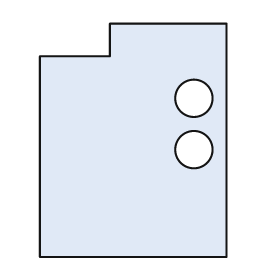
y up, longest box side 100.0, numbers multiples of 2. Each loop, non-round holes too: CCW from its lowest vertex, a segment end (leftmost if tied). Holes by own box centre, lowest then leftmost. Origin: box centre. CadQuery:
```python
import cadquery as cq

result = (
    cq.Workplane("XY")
    .moveTo(-40.0, -50.0)
    .lineTo(40.0, -50.0)
    .lineTo(40.0, 50.0)
    .lineTo(-10.0, 50.0)
    .lineTo(-10.0, 36.0)
    .lineTo(-40.0, 36.0)
    .close()
    .moveTo(26.0, -4.0)
    .circle(8.0)
    .moveTo(26.0, 18.0)
    .circle(8.0)
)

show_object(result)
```